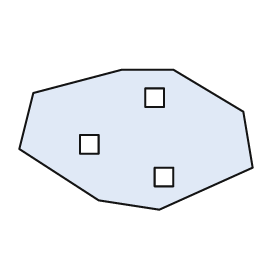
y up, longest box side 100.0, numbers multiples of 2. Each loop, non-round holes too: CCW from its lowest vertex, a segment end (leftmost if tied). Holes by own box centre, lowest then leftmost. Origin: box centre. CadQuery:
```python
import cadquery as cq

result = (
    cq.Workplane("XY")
    .moveTo(10.0, -30.0)
    .lineTo(50.0, -12.0)
    .lineTo(46.0, 12.0)
    .lineTo(16.0, 30.0)
    .lineTo(-6.0, 30.0)
    .lineTo(-44.0, 20.0)
    .lineTo(-50.0, -4.0)
    .lineTo(-16.0, -26.0)
    .close()
    .moveTo(8.0, -20.0)
    .lineTo(16.0, -20.0)
    .lineTo(16.0, -12.0)
    .lineTo(8.0, -12.0)
    .close()
    .moveTo(-24.0, -6.0)
    .lineTo(-16.0, -6.0)
    .lineTo(-16.0, 2.0)
    .lineTo(-24.0, 2.0)
    .close()
    .moveTo(4.0, 14.0)
    .lineTo(12.0, 14.0)
    .lineTo(12.0, 22.0)
    .lineTo(4.0, 22.0)
    .close()
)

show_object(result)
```